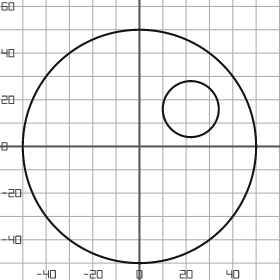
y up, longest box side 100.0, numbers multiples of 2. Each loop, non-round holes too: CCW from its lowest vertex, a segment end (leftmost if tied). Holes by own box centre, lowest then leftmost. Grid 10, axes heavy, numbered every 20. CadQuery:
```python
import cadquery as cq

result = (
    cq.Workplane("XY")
    .moveTo(0.0, 0.0)
    .circle(50.0)
    .moveTo(22.0, 16.0)
    .circle(12.0)
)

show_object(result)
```